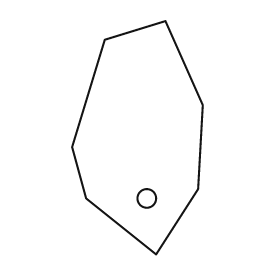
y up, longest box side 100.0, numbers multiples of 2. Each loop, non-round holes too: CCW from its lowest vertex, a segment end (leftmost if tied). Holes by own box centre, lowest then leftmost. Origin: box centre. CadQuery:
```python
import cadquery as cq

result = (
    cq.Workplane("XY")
    .moveTo(8.0, -50.0)
    .lineTo(26.0, -22.0)
    .lineTo(28.0, 14.0)
    .lineTo(12.0, 50.0)
    .lineTo(-14.0, 42.0)
    .lineTo(-28.0, -4.0)
    .lineTo(-22.0, -26.0)
    .close()
    .moveTo(4.0, -26.0)
    .circle(4.0)
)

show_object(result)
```